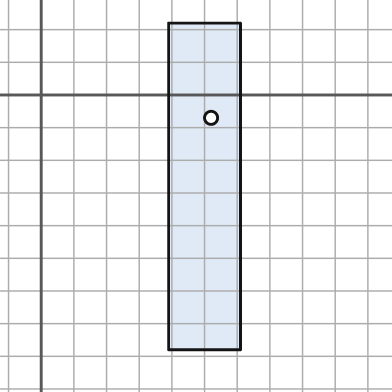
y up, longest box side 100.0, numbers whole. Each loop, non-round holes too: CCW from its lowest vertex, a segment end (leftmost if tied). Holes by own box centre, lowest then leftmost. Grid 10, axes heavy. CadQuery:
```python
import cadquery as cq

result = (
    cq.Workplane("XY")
    .moveTo(39.0, -78.0)
    .lineTo(61.0, -78.0)
    .lineTo(61.0, 22.0)
    .lineTo(39.0, 22.0)
    .close()
    .moveTo(52.0, -7.0)
    .circle(2.0)
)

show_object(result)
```